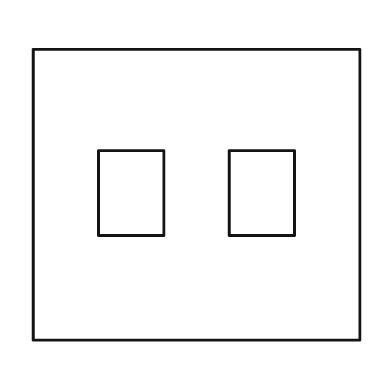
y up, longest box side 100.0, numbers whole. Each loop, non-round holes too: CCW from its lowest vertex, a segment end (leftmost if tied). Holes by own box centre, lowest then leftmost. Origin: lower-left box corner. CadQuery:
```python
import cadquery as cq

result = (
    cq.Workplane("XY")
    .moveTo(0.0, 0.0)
    .lineTo(100.0, 0.0)
    .lineTo(100.0, 89.0)
    .lineTo(0.0, 89.0)
    .close()
    .moveTo(20.0, 32.0)
    .lineTo(40.0, 32.0)
    .lineTo(40.0, 58.0)
    .lineTo(20.0, 58.0)
    .close()
    .moveTo(60.0, 32.0)
    .lineTo(80.0, 32.0)
    .lineTo(80.0, 58.0)
    .lineTo(60.0, 58.0)
    .close()
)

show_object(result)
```